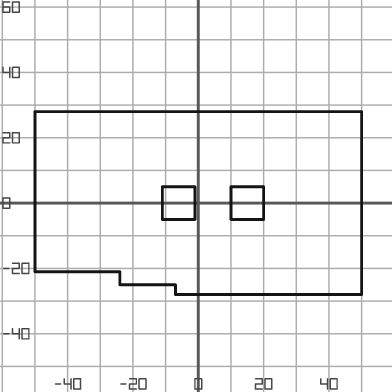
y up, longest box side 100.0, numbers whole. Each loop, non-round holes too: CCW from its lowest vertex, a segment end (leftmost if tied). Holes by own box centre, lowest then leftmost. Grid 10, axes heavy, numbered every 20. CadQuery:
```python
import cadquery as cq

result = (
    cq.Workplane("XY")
    .moveTo(-7.0, -28.0)
    .lineTo(50.0, -28.0)
    .lineTo(50.0, 28.0)
    .lineTo(-50.0, 28.0)
    .lineTo(-50.0, -21.0)
    .lineTo(-24.0, -21.0)
    .lineTo(-24.0, -25.0)
    .lineTo(-7.0, -25.0)
    .close()
    .moveTo(-11.0, -5.0)
    .lineTo(-1.0, -5.0)
    .lineTo(-1.0, 5.0)
    .lineTo(-11.0, 5.0)
    .close()
    .moveTo(10.0, -5.0)
    .lineTo(20.0, -5.0)
    .lineTo(20.0, 5.0)
    .lineTo(10.0, 5.0)
    .close()
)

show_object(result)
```